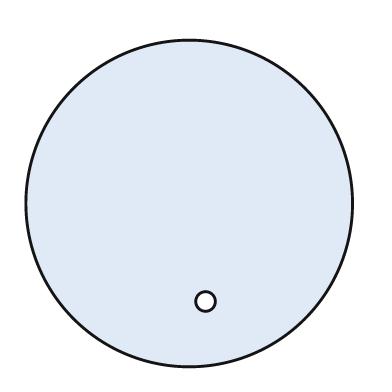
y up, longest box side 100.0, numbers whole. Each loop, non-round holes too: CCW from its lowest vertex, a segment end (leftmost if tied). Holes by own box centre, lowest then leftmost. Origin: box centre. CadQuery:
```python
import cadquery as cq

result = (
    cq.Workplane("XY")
    .moveTo(0.0, 0.0)
    .circle(50.0)
    .moveTo(5.0, -30.0)
    .circle(3.0)
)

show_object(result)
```